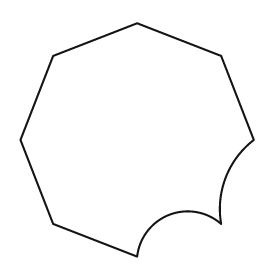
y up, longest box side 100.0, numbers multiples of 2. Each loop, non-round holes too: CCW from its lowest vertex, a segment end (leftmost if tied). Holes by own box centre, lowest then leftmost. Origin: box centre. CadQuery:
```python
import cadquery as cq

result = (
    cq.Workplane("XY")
    .moveTo(0.0, -50.0)
    .threePointArc((14.0, -32.0), (36.0, -36.0))
    .threePointArc((38.0, -16.0), (50.0, 0.0))
    .lineTo(36.0, 36.0)
    .lineTo(0.0, 50.0)
    .lineTo(-36.0, 36.0)
    .lineTo(-50.0, 0.0)
    .lineTo(-36.0, -36.0)
    .close()
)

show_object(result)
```